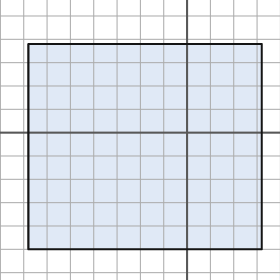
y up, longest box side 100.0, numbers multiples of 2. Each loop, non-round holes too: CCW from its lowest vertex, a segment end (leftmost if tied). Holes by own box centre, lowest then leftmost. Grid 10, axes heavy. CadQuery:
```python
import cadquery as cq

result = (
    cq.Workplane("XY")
    .moveTo(-68.0, -50.0)
    .lineTo(32.0, -50.0)
    .lineTo(32.0, 38.0)
    .lineTo(-68.0, 38.0)
    .close()
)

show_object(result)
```